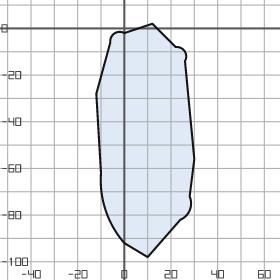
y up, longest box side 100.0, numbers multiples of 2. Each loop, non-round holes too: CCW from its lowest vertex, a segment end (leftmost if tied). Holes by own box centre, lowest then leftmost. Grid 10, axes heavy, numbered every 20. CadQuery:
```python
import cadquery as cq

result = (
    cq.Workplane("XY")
    .moveTo(10.0, -98.0)
    .lineTo(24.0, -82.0)
    .threePointArc((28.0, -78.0), (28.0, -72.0))
    .lineTo(30.0, -56.0)
    .lineTo(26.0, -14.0)
    .threePointArc((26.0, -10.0), (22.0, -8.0))
    .lineTo(12.0, 2.0)
    .lineTo(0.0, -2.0)
    .threePointArc((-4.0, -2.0), (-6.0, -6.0))
    .lineTo(-12.0, -28.0)
    .lineTo(-10.0, -62.0)
    .threePointArc((-8.0, -78.0), (0.0, -92.0))
    .close()
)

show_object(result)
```